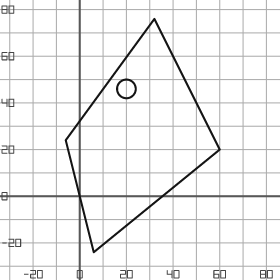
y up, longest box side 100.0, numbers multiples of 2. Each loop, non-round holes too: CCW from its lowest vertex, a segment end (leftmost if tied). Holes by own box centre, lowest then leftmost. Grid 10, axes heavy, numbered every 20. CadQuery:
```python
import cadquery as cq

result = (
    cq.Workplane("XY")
    .moveTo(6.0, -24.0)
    .lineTo(60.0, 20.0)
    .lineTo(32.0, 76.0)
    .lineTo(-6.0, 24.0)
    .close()
    .moveTo(20.0, 46.0)
    .circle(4.0)
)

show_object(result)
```